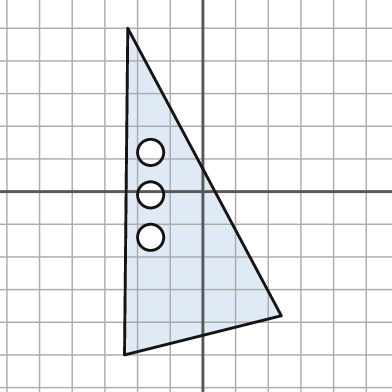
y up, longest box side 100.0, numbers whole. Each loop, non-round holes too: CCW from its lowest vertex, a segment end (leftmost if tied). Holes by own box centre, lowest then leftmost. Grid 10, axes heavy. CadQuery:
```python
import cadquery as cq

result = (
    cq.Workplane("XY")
    .moveTo(-24.0, -50.0)
    .lineTo(24.0, -38.0)
    .lineTo(-23.0, 50.0)
    .close()
    .moveTo(-16.0, -14.0)
    .circle(4.0)
    .moveTo(-16.0, -1.0)
    .circle(4.0)
    .moveTo(-16.0, 12.0)
    .circle(4.0)
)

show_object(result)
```